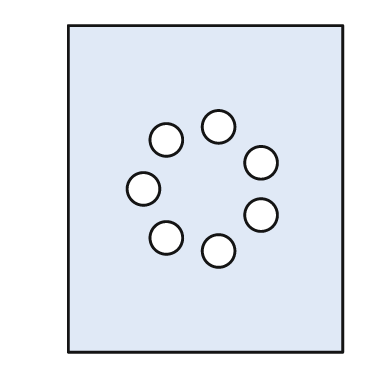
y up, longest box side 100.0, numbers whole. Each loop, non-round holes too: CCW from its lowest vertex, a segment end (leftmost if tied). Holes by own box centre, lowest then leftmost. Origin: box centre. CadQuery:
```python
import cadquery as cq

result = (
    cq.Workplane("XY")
    .moveTo(-42.0, -50.0)
    .lineTo(42.0, -50.0)
    .lineTo(42.0, 50.0)
    .lineTo(-42.0, 50.0)
    .close()
    .moveTo(4.0, -19.0)
    .circle(5.0)
    .moveTo(-12.0, -15.0)
    .circle(5.0)
    .moveTo(17.0, -8.0)
    .circle(5.0)
    .moveTo(-19.0, 0.0)
    .circle(5.0)
    .moveTo(17.0, 8.0)
    .circle(5.0)
    .moveTo(-12.0, 15.0)
    .circle(5.0)
    .moveTo(4.0, 19.0)
    .circle(5.0)
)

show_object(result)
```